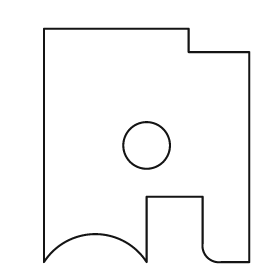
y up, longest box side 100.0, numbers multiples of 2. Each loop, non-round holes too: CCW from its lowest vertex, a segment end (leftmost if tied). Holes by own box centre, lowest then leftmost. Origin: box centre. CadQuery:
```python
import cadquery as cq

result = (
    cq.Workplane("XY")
    .moveTo(-44.0, -50.0)
    .threePointArc((-22.0, -38.0), (0.0, -50.0))
    .lineTo(0.0, -22.0)
    .lineTo(24.0, -22.0)
    .lineTo(24.0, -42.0)
    .threePointArc((26.0, -48.0), (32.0, -50.0))
    .lineTo(44.0, -50.0)
    .lineTo(44.0, 40.0)
    .lineTo(18.0, 40.0)
    .lineTo(18.0, 50.0)
    .lineTo(-44.0, 50.0)
    .close()
    .moveTo(0.0, 0.0)
    .circle(10.0)
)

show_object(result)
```